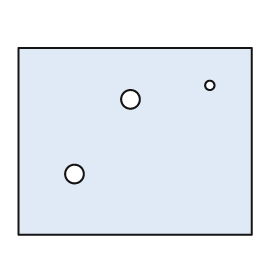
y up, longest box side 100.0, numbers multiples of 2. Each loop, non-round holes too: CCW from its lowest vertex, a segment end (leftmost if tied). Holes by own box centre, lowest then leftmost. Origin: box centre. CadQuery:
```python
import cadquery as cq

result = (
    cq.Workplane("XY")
    .moveTo(-50.0, -40.0)
    .lineTo(50.0, -40.0)
    .lineTo(50.0, 40.0)
    .lineTo(-50.0, 40.0)
    .close()
    .moveTo(-26.0, -14.0)
    .circle(4.0)
    .moveTo(-2.0, 18.0)
    .circle(4.0)
    .moveTo(32.0, 24.0)
    .circle(2.0)
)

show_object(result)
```